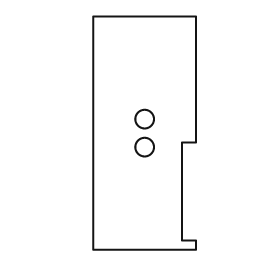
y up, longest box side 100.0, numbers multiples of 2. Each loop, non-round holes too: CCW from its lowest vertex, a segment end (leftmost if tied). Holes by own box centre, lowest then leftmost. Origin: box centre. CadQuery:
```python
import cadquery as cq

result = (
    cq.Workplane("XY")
    .moveTo(-22.0, -50.0)
    .lineTo(22.0, -50.0)
    .lineTo(22.0, -46.0)
    .lineTo(16.0, -46.0)
    .lineTo(16.0, -4.0)
    .lineTo(22.0, -4.0)
    .lineTo(22.0, 50.0)
    .lineTo(-22.0, 50.0)
    .close()
    .moveTo(0.0, -6.0)
    .circle(4.0)
    .moveTo(0.0, 6.0)
    .circle(4.0)
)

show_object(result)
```